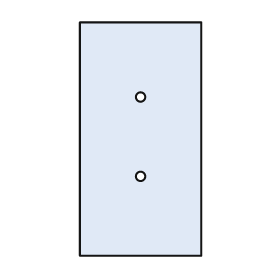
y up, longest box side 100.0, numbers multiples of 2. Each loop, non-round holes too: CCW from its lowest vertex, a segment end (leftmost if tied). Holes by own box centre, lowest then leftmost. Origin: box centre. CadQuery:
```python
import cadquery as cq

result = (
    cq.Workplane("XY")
    .moveTo(-26.0, -50.0)
    .lineTo(26.0, -50.0)
    .lineTo(26.0, 50.0)
    .lineTo(-26.0, 50.0)
    .close()
    .moveTo(0.0, -16.0)
    .circle(2.0)
    .moveTo(0.0, 18.0)
    .circle(2.0)
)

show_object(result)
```